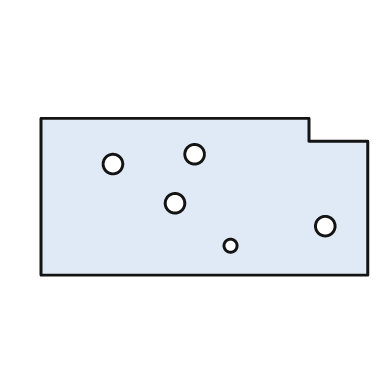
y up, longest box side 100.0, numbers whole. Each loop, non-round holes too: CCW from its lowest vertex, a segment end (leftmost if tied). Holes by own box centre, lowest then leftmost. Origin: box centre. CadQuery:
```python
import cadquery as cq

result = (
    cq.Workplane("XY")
    .moveTo(-50.0, -24.0)
    .lineTo(50.0, -24.0)
    .lineTo(50.0, 17.0)
    .lineTo(32.0, 17.0)
    .lineTo(32.0, 24.0)
    .lineTo(-50.0, 24.0)
    .close()
    .moveTo(8.0, -15.0)
    .circle(2.0)
    .moveTo(37.0, -9.0)
    .circle(3.0)
    .moveTo(-9.0, -2.0)
    .circle(3.0)
    .moveTo(-28.0, 10.0)
    .circle(3.0)
    .moveTo(-3.0, 13.0)
    .circle(3.0)
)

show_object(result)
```